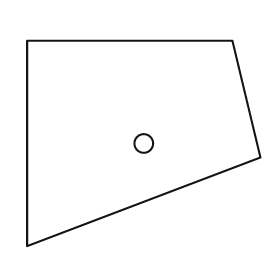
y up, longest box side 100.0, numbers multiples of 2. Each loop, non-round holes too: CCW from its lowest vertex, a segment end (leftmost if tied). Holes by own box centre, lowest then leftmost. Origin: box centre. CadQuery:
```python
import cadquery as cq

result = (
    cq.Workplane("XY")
    .moveTo(-50.0, -44.0)
    .lineTo(50.0, -6.0)
    .lineTo(38.0, 44.0)
    .lineTo(-50.0, 44.0)
    .close()
    .moveTo(0.0, 0.0)
    .circle(4.0)
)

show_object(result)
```